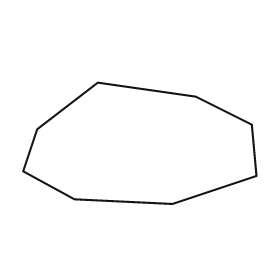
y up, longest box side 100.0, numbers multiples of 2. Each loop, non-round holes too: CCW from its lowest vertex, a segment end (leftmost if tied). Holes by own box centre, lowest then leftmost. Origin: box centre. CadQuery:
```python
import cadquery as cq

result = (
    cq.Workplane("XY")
    .moveTo(14.0, -26.0)
    .lineTo(50.0, -14.0)
    .lineTo(48.0, 8.0)
    .lineTo(24.0, 20.0)
    .lineTo(-18.0, 26.0)
    .lineTo(-44.0, 6.0)
    .lineTo(-50.0, -12.0)
    .lineTo(-28.0, -24.0)
    .close()
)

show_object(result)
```